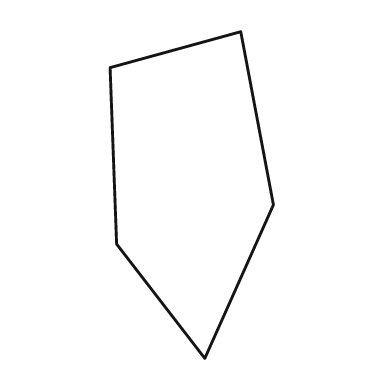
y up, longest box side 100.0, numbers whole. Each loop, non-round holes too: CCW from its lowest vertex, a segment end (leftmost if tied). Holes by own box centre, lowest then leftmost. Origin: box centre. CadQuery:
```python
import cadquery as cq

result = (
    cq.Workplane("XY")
    .moveTo(4.0, -50.0)
    .lineTo(25.0, -3.0)
    .lineTo(15.0, 50.0)
    .lineTo(-25.0, 39.0)
    .lineTo(-23.0, -15.0)
    .close()
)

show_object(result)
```